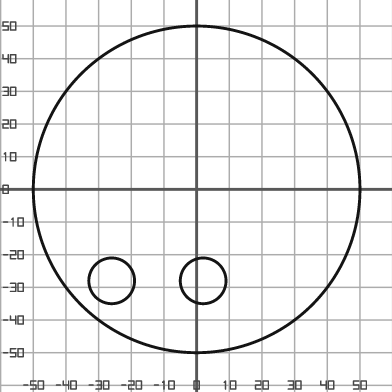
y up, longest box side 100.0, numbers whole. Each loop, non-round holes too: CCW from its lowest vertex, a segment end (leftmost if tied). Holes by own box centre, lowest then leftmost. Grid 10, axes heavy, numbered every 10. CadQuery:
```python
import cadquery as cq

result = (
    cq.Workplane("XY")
    .moveTo(0.0, 0.0)
    .circle(50.0)
    .moveTo(-26.0, -28.0)
    .circle(7.0)
    .moveTo(2.0, -28.0)
    .circle(7.0)
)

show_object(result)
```